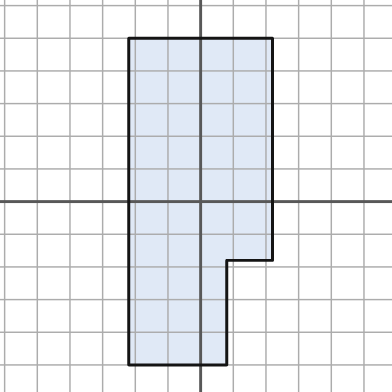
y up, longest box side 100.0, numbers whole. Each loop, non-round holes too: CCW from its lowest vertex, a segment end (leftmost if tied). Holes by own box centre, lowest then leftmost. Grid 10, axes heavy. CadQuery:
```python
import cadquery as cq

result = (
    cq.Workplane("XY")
    .moveTo(-22.0, -50.0)
    .lineTo(8.0, -50.0)
    .lineTo(8.0, -18.0)
    .lineTo(22.0, -18.0)
    .lineTo(22.0, 50.0)
    .lineTo(-22.0, 50.0)
    .close()
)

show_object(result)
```